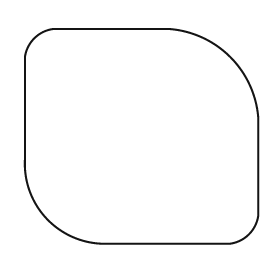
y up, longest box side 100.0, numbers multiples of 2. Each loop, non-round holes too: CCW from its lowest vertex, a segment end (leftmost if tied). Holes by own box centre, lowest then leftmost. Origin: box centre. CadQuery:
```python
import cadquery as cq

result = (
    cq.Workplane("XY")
    .moveTo(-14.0, -46.0)
    .lineTo(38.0, -46.0)
    .threePointArc((46.0, -42.0), (50.0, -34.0))
    .lineTo(50.0, 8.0)
    .threePointArc((38.0, 34.0), (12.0, 46.0))
    .lineTo(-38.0, 46.0)
    .threePointArc((-46.0, 42.0), (-50.0, 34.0))
    .lineTo(-50.0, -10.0)
    .threePointArc((-40.0, -36.0), (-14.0, -46.0))
    .close()
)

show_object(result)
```